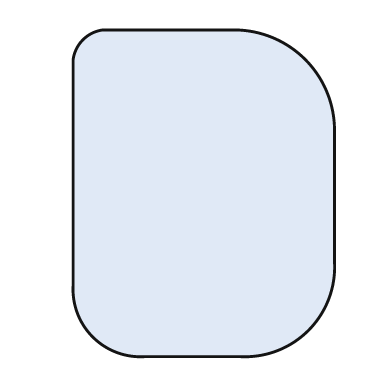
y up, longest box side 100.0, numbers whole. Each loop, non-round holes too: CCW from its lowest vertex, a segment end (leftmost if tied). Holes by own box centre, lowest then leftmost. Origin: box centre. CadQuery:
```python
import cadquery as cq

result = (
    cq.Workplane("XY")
    .moveTo(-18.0, -50.0)
    .lineTo(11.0, -50.0)
    .threePointArc((32.0, -42.0), (40.0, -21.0))
    .lineTo(40.0, 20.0)
    .threePointArc((31.0, 41.0), (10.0, 50.0))
    .lineTo(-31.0, 50.0)
    .threePointArc((-37.0, 47.0), (-40.0, 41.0))
    .lineTo(-40.0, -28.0)
    .threePointArc((-34.0, -44.0), (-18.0, -50.0))
    .close()
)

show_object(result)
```